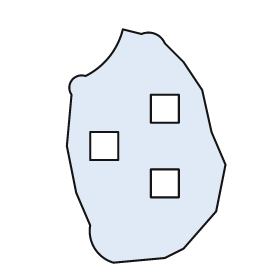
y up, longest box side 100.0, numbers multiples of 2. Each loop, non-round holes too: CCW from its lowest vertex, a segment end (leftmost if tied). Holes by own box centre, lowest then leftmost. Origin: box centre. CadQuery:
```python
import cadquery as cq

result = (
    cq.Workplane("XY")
    .moveTo(-14.0, -50.0)
    .lineTo(8.0, -48.0)
    .lineTo(16.0, -44.0)
    .lineTo(30.0, -28.0)
    .lineTo(34.0, -8.0)
    .lineTo(28.0, 6.0)
    .lineTo(24.0, 24.0)
    .lineTo(16.0, 36.0)
    .lineTo(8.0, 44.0)
    .threePointArc((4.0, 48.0), (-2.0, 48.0))
    .lineTo(-10.0, 50.0)
    .threePointArc((-16.0, 38.0), (-26.0, 30.0))
    .threePointArc((-32.0, 28.0), (-32.0, 22.0))
    .lineTo(-34.0, 0.0)
    .lineTo(-30.0, -20.0)
    .lineTo(-24.0, -34.0)
    .threePointArc((-22.0, -44.0), (-14.0, -50.0))
    .close()
    .moveTo(2.0, -22.0)
    .lineTo(14.0, -22.0)
    .lineTo(14.0, -10.0)
    .lineTo(2.0, -10.0)
    .close()
    .moveTo(-24.0, -6.0)
    .lineTo(-12.0, -6.0)
    .lineTo(-12.0, 6.0)
    .lineTo(-24.0, 6.0)
    .close()
    .moveTo(2.0, 10.0)
    .lineTo(14.0, 10.0)
    .lineTo(14.0, 22.0)
    .lineTo(2.0, 22.0)
    .close()
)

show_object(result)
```